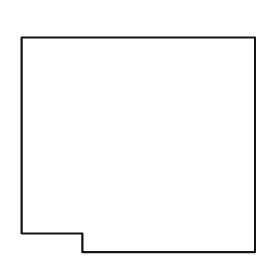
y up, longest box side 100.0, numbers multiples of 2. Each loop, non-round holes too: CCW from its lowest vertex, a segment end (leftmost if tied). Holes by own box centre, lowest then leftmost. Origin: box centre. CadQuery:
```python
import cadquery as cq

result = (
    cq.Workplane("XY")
    .moveTo(-24.0, -46.0)
    .lineTo(50.0, -46.0)
    .lineTo(50.0, 46.0)
    .lineTo(-50.0, 46.0)
    .lineTo(-50.0, -38.0)
    .lineTo(-24.0, -38.0)
    .close()
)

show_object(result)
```